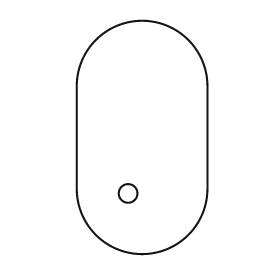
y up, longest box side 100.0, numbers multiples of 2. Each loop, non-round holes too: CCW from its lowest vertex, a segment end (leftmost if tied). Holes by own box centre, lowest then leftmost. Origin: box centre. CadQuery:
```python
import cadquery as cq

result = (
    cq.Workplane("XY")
    .moveTo(-28.0, -22.0)
    .threePointArc((0.0, -50.0), (28.0, -22.0))
    .lineTo(28.0, 22.0)
    .threePointArc((0.0, 50.0), (-28.0, 22.0))
    .close()
    .moveTo(-6.0, -24.0)
    .circle(4.0)
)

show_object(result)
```